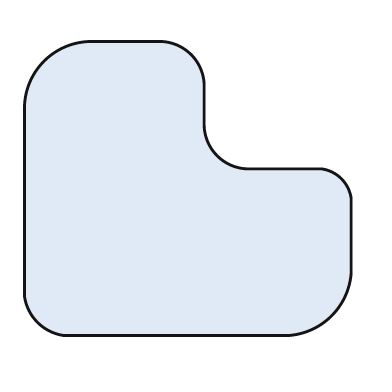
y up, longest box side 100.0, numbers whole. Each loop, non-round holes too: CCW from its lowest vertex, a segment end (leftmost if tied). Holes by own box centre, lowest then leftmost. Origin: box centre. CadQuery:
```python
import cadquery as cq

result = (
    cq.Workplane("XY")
    .moveTo(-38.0, -45.0)
    .lineTo(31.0, -45.0)
    .threePointArc((44.0, -39.0), (50.0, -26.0))
    .lineTo(50.0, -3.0)
    .threePointArc((47.0, 3.0), (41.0, 6.0))
    .lineTo(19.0, 6.0)
    .threePointArc((9.0, 10.0), (5.0, 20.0))
    .lineTo(5.0, 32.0)
    .threePointArc((1.0, 41.0), (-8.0, 45.0))
    .lineTo(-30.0, 45.0)
    .threePointArc((-44.0, 39.0), (-50.0, 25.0))
    .lineTo(-50.0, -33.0)
    .threePointArc((-46.0, -41.0), (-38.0, -45.0))
    .close()
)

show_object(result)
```